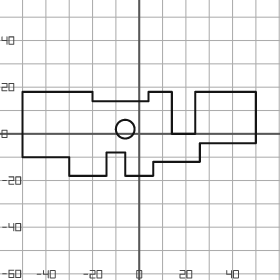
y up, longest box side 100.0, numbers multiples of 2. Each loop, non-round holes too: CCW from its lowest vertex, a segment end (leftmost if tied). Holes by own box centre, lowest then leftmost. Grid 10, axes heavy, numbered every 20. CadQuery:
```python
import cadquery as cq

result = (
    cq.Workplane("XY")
    .moveTo(-30.0, -18.0)
    .lineTo(-14.0, -18.0)
    .lineTo(-14.0, -8.0)
    .lineTo(-6.0, -8.0)
    .lineTo(-6.0, -18.0)
    .lineTo(6.0, -18.0)
    .lineTo(6.0, -12.0)
    .lineTo(26.0, -12.0)
    .lineTo(26.0, -4.0)
    .lineTo(50.0, -4.0)
    .lineTo(50.0, 18.0)
    .lineTo(24.0, 18.0)
    .lineTo(24.0, 0.0)
    .lineTo(14.0, 0.0)
    .lineTo(14.0, 18.0)
    .lineTo(4.0, 18.0)
    .lineTo(4.0, 14.0)
    .lineTo(-20.0, 14.0)
    .lineTo(-20.0, 18.0)
    .lineTo(-50.0, 18.0)
    .lineTo(-50.0, -10.0)
    .lineTo(-30.0, -10.0)
    .close()
    .moveTo(-6.0, 2.0)
    .circle(4.0)
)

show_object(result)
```